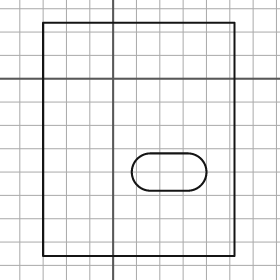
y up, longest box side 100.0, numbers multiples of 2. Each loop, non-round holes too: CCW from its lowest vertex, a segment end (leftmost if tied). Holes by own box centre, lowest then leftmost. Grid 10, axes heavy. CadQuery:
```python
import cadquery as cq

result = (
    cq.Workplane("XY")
    .moveTo(-30.0, -76.0)
    .lineTo(52.0, -76.0)
    .lineTo(52.0, 24.0)
    .lineTo(-30.0, 24.0)
    .close()
    .moveTo(16.0, -48.0)
    .lineTo(32.0, -48.0)
    .threePointArc((40.0, -40.0), (32.0, -32.0))
    .lineTo(16.0, -32.0)
    .threePointArc((8.0, -40.0), (16.0, -48.0))
    .close()
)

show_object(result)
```